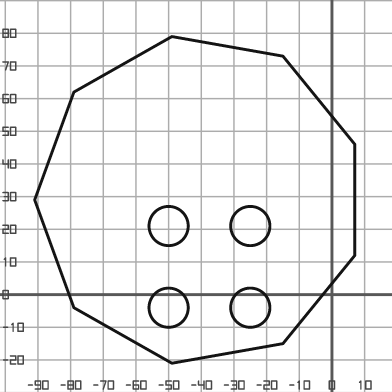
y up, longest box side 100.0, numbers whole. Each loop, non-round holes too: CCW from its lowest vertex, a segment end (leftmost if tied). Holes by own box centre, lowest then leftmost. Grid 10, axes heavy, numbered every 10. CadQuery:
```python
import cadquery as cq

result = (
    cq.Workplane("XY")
    .moveTo(-49.0, -21.0)
    .lineTo(-15.0, -15.0)
    .lineTo(7.0, 12.0)
    .lineTo(7.0, 46.0)
    .lineTo(-15.0, 73.0)
    .lineTo(-49.0, 79.0)
    .lineTo(-79.0, 62.0)
    .lineTo(-91.0, 29.0)
    .lineTo(-79.0, -4.0)
    .close()
    .moveTo(-50.0, -4.0)
    .circle(6.0)
    .moveTo(-25.0, -4.0)
    .circle(6.0)
    .moveTo(-50.0, 21.0)
    .circle(6.0)
    .moveTo(-25.0, 21.0)
    .circle(6.0)
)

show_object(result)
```